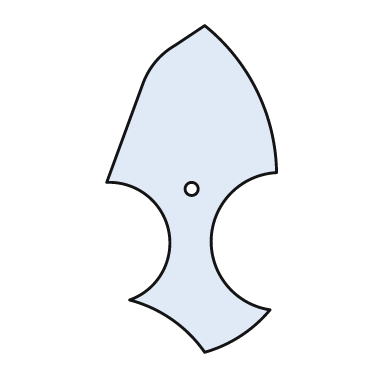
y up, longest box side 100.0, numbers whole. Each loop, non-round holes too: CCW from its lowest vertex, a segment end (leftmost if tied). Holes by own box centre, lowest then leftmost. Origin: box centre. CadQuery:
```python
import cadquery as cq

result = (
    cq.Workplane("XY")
    .moveTo(4.0, -50.0)
    .threePointArc((15.0, -45.0), (24.0, -37.0))
    .threePointArc((6.0, -15.0), (26.0, 5.0))
    .threePointArc((20.0, 30.0), (4.0, 50.0))
    .lineTo(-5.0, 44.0)
    .threePointArc((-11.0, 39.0), (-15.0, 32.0))
    .lineTo(-26.0, 2.0)
    .threePointArc((-7.0, -13.0), (-19.0, -34.0))
    .threePointArc((-6.0, -40.0), (4.0, -50.0))
    .close()
    .moveTo(0.0, 0.0)
    .circle(2.0)
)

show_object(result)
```